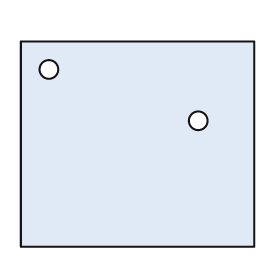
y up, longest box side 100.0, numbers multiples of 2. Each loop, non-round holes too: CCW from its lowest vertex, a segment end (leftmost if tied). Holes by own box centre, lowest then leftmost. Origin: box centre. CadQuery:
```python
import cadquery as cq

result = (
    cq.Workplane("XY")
    .moveTo(-50.0, -44.0)
    .lineTo(50.0, -44.0)
    .lineTo(50.0, 44.0)
    .lineTo(-50.0, 44.0)
    .close()
    .moveTo(26.0, 10.0)
    .circle(4.0)
    .moveTo(-38.0, 32.0)
    .circle(4.0)
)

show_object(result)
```